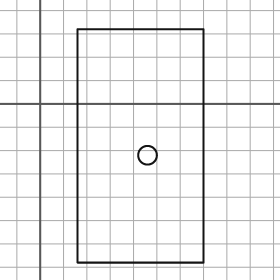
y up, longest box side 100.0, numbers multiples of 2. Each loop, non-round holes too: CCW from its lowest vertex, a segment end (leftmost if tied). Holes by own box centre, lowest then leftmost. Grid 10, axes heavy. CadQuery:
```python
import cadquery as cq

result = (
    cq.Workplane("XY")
    .moveTo(16.0, -68.0)
    .lineTo(70.0, -68.0)
    .lineTo(70.0, 32.0)
    .lineTo(16.0, 32.0)
    .close()
    .moveTo(46.0, -22.0)
    .circle(4.0)
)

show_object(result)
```